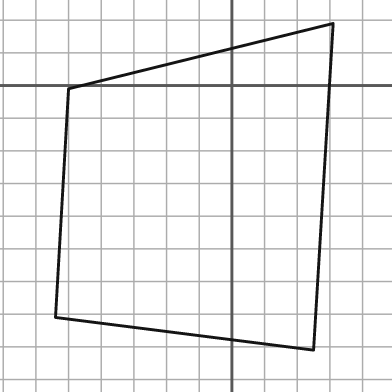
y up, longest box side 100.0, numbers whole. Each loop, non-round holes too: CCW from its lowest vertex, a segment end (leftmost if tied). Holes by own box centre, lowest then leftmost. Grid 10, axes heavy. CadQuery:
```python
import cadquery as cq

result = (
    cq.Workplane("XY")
    .moveTo(25.0, -81.0)
    .lineTo(31.0, 19.0)
    .lineTo(-50.0, -1.0)
    .lineTo(-54.0, -71.0)
    .close()
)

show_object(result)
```